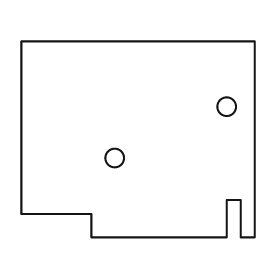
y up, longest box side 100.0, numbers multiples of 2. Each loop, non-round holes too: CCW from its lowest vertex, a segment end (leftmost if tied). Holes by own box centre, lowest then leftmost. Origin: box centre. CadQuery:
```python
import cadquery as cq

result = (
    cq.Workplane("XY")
    .moveTo(-20.0, -42.0)
    .lineTo(38.0, -42.0)
    .lineTo(38.0, -26.0)
    .lineTo(44.0, -26.0)
    .lineTo(44.0, -42.0)
    .lineTo(50.0, -42.0)
    .lineTo(50.0, 42.0)
    .lineTo(-50.0, 42.0)
    .lineTo(-50.0, -32.0)
    .lineTo(-20.0, -32.0)
    .close()
    .moveTo(-10.0, -8.0)
    .circle(4.0)
    .moveTo(38.0, 14.0)
    .circle(4.0)
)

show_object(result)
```